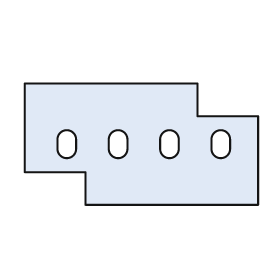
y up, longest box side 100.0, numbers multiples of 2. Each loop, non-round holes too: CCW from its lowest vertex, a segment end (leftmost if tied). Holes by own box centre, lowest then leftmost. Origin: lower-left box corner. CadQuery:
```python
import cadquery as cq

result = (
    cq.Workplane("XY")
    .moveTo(26.0, 0.0)
    .lineTo(100.0, 0.0)
    .lineTo(100.0, 38.0)
    .lineTo(74.0, 38.0)
    .lineTo(74.0, 52.0)
    .lineTo(0.0, 52.0)
    .lineTo(0.0, 14.0)
    .lineTo(26.0, 14.0)
    .close()
    .moveTo(14.0, 24.0)
    .threePointArc((18.0, 20.0), (22.0, 24.0))
    .lineTo(22.0, 28.0)
    .threePointArc((18.0, 32.0), (14.0, 28.0))
    .close()
    .moveTo(36.0, 24.0)
    .threePointArc((40.0, 20.0), (44.0, 24.0))
    .lineTo(44.0, 28.0)
    .threePointArc((40.0, 32.0), (36.0, 28.0))
    .close()
    .moveTo(58.0, 24.0)
    .threePointArc((62.0, 20.0), (66.0, 24.0))
    .lineTo(66.0, 28.0)
    .threePointArc((62.0, 32.0), (58.0, 28.0))
    .close()
    .moveTo(80.0, 24.0)
    .threePointArc((84.0, 20.0), (88.0, 24.0))
    .lineTo(88.0, 28.0)
    .threePointArc((84.0, 32.0), (80.0, 28.0))
    .close()
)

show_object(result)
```